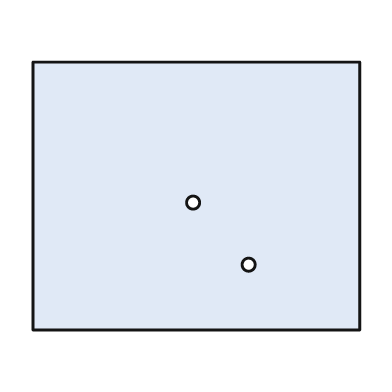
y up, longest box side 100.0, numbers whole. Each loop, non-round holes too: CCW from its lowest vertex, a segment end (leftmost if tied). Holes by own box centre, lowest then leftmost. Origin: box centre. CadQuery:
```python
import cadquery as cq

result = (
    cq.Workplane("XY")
    .moveTo(-50.0, -41.0)
    .lineTo(50.0, -41.0)
    .lineTo(50.0, 41.0)
    .lineTo(-50.0, 41.0)
    .close()
    .moveTo(16.0, -21.0)
    .circle(2.0)
    .moveTo(-1.0, -2.0)
    .circle(2.0)
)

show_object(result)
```